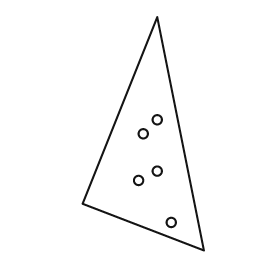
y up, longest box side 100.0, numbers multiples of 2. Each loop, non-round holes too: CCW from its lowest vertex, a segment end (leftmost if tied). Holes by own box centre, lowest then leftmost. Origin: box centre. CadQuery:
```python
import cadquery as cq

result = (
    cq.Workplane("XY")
    .moveTo(26.0, -50.0)
    .lineTo(6.0, 50.0)
    .lineTo(-26.0, -30.0)
    .close()
    .moveTo(12.0, -38.0)
    .circle(2.0)
    .moveTo(-2.0, -20.0)
    .circle(2.0)
    .moveTo(6.0, -16.0)
    .circle(2.0)
    .moveTo(0.0, 0.0)
    .circle(2.0)
    .moveTo(6.0, 6.0)
    .circle(2.0)
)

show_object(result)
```